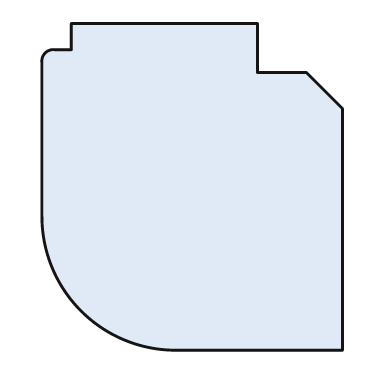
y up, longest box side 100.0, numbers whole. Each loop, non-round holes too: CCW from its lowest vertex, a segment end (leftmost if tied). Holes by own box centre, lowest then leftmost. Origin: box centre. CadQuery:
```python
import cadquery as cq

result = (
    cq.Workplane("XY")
    .moveTo(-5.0, -50.0)
    .lineTo(46.0, -50.0)
    .lineTo(46.0, 24.0)
    .lineTo(35.0, 35.0)
    .lineTo(20.0, 35.0)
    .lineTo(20.0, 50.0)
    .lineTo(-37.0, 50.0)
    .lineTo(-37.0, 42.0)
    .lineTo(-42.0, 42.0)
    .threePointArc((-45.0, 41.0), (-46.0, 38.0))
    .lineTo(-46.0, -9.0)
    .threePointArc((-34.0, -38.0), (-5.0, -50.0))
    .close()
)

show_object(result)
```